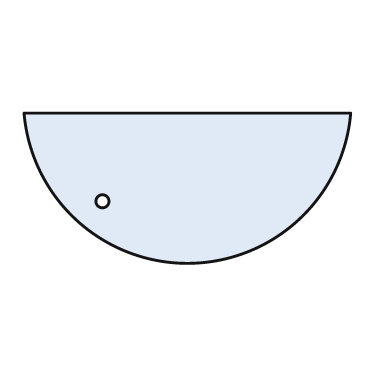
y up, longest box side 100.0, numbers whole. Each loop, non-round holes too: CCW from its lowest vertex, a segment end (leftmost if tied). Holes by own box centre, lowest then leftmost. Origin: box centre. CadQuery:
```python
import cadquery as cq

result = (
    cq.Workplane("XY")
    .moveTo(-50.0, 23.0)
    .threePointArc((0.0, -23.0), (50.0, 23.0))
    .close()
    .moveTo(-26.0, -4.0)
    .circle(2.0)
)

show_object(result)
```